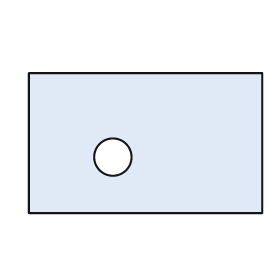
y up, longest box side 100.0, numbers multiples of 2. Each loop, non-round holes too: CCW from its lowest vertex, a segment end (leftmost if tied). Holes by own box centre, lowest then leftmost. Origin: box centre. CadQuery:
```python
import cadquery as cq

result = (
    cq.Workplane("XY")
    .moveTo(-50.0, -30.0)
    .lineTo(50.0, -30.0)
    .lineTo(50.0, 30.0)
    .lineTo(-50.0, 30.0)
    .close()
    .moveTo(-14.0, -6.0)
    .circle(8.0)
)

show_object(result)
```